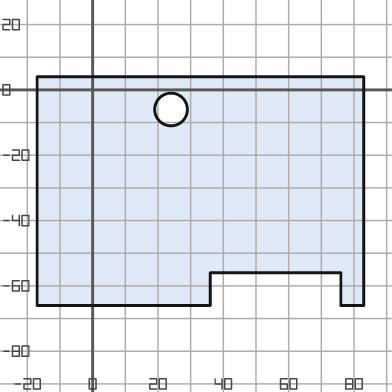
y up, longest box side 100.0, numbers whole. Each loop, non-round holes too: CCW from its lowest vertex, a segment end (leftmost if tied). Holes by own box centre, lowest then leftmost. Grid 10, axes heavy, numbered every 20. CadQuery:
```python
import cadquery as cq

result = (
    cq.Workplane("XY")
    .moveTo(-17.0, -66.0)
    .lineTo(36.0, -66.0)
    .lineTo(36.0, -56.0)
    .lineTo(76.0, -56.0)
    .lineTo(76.0, -66.0)
    .lineTo(83.0, -66.0)
    .lineTo(83.0, 4.0)
    .lineTo(-17.0, 4.0)
    .close()
    .moveTo(24.0, -6.0)
    .circle(5.0)
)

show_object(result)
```